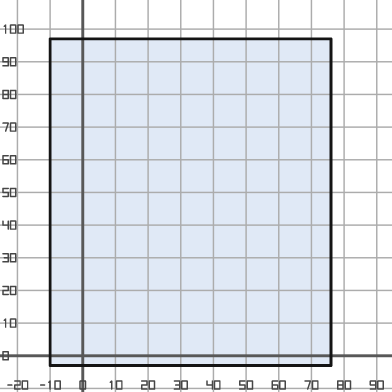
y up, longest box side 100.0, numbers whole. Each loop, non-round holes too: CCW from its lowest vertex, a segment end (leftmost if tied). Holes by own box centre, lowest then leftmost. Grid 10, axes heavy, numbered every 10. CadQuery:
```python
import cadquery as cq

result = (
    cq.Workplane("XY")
    .moveTo(-10.0, -3.0)
    .lineTo(76.0, -3.0)
    .lineTo(76.0, 97.0)
    .lineTo(-10.0, 97.0)
    .close()
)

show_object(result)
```